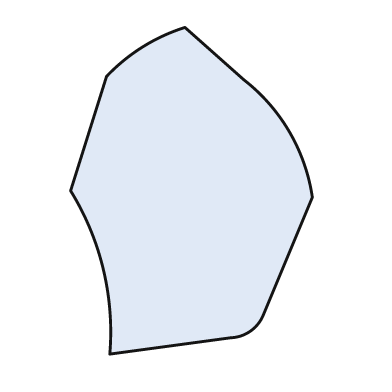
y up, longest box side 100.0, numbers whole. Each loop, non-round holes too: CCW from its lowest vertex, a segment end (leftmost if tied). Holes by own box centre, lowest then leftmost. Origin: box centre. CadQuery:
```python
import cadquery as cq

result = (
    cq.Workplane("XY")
    .moveTo(-25.0, -50.0)
    .lineTo(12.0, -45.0)
    .threePointArc((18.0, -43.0), (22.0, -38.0))
    .lineTo(37.0, -2.0)
    .threePointArc((30.0, 18.0), (16.0, 34.0))
    .lineTo(-2.0, 50.0)
    .threePointArc((-15.0, 44.0), (-26.0, 35.0))
    .lineTo(-37.0, 0.0)
    .threePointArc((-27.0, -24.0), (-25.0, -50.0))
    .close()
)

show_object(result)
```